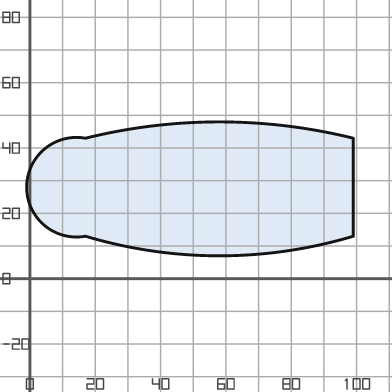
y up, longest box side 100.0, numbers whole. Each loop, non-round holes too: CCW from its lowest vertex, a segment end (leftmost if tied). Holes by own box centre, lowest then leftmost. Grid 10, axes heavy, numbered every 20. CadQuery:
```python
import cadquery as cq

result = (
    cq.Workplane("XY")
    .moveTo(17.0, 13.0)
    .threePointArc((58.0, 7.0), (99.0, 13.0))
    .lineTo(99.0, 43.0)
    .threePointArc((58.0, 48.0), (17.0, 43.0))
    .threePointArc((-1.0, 28.0), (17.0, 13.0))
    .close()
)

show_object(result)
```